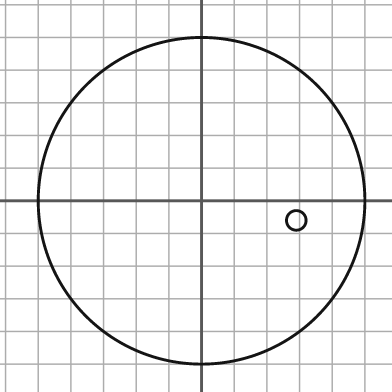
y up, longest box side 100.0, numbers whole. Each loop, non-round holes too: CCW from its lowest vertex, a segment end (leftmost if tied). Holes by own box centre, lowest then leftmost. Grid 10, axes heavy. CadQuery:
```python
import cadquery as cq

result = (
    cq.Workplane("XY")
    .moveTo(0.0, 0.0)
    .circle(50.0)
    .moveTo(29.0, -6.0)
    .circle(3.0)
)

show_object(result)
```